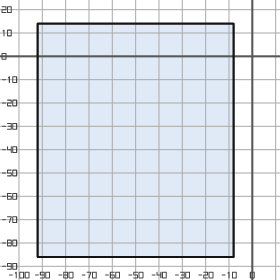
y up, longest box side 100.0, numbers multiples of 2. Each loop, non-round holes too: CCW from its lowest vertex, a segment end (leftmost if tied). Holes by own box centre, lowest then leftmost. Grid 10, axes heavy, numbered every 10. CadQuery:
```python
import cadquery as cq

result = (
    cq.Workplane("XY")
    .moveTo(-92.0, -86.0)
    .lineTo(-8.0, -86.0)
    .lineTo(-8.0, 14.0)
    .lineTo(-92.0, 14.0)
    .close()
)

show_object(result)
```